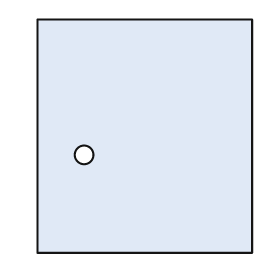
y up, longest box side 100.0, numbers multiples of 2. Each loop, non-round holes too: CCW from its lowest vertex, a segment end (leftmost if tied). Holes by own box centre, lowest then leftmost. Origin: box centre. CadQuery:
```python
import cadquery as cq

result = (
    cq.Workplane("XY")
    .moveTo(-46.0, -50.0)
    .lineTo(46.0, -50.0)
    .lineTo(46.0, 50.0)
    .lineTo(-46.0, 50.0)
    .close()
    .moveTo(-26.0, -8.0)
    .circle(4.0)
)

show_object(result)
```